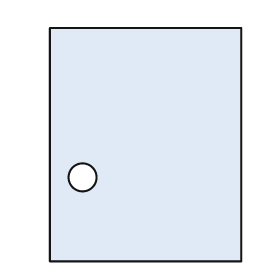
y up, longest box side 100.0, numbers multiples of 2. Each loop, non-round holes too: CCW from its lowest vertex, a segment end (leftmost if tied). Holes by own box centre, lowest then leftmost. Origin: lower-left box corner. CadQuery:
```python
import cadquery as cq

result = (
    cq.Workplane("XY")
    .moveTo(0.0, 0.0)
    .lineTo(82.0, 0.0)
    .lineTo(82.0, 100.0)
    .lineTo(0.0, 100.0)
    .close()
    .moveTo(14.0, 36.0)
    .circle(6.0)
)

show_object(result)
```